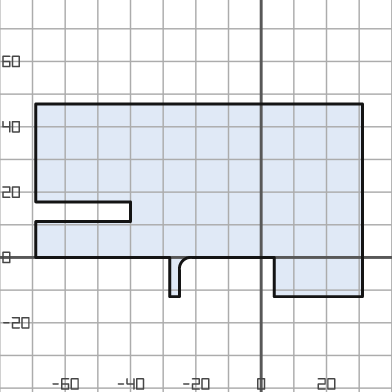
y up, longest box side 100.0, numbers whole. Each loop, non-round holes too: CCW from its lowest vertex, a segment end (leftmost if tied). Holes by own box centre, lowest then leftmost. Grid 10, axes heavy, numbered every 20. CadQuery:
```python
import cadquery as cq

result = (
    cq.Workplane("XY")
    .moveTo(-28.0, -12.0)
    .lineTo(-25.0, -12.0)
    .lineTo(-25.0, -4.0)
    .threePointArc((-24.0, -1.0), (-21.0, 0.0))
    .lineTo(4.0, 0.0)
    .lineTo(4.0, -12.0)
    .lineTo(31.0, -12.0)
    .lineTo(31.0, 47.0)
    .lineTo(-69.0, 47.0)
    .lineTo(-69.0, 17.0)
    .lineTo(-40.0, 17.0)
    .lineTo(-40.0, 11.0)
    .lineTo(-69.0, 11.0)
    .lineTo(-69.0, 0.0)
    .lineTo(-28.0, 0.0)
    .close()
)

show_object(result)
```